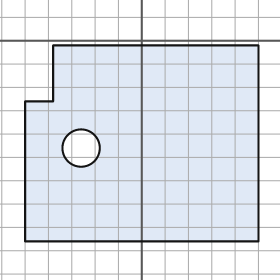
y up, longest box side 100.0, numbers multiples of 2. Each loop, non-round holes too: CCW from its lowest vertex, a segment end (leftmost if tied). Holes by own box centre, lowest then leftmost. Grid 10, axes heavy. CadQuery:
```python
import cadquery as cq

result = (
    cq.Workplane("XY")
    .moveTo(-50.0, -86.0)
    .lineTo(50.0, -86.0)
    .lineTo(50.0, -2.0)
    .lineTo(-38.0, -2.0)
    .lineTo(-38.0, -26.0)
    .lineTo(-50.0, -26.0)
    .close()
    .moveTo(-26.0, -46.0)
    .circle(8.0)
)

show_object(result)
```